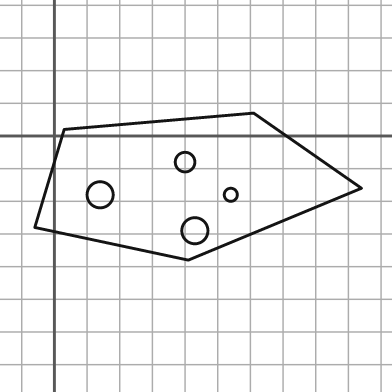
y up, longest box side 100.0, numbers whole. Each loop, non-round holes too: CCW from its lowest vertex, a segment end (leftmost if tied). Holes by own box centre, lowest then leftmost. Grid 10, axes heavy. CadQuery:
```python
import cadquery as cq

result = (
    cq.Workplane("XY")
    .moveTo(41.0, -38.0)
    .lineTo(94.0, -16.0)
    .lineTo(61.0, 7.0)
    .lineTo(3.0, 2.0)
    .lineTo(-6.0, -28.0)
    .close()
    .moveTo(43.0, -29.0)
    .circle(4.0)
    .moveTo(14.0, -18.0)
    .circle(4.0)
    .moveTo(54.0, -18.0)
    .circle(2.0)
    .moveTo(40.0, -8.0)
    .circle(3.0)
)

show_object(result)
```